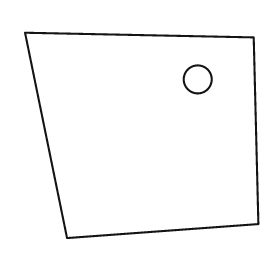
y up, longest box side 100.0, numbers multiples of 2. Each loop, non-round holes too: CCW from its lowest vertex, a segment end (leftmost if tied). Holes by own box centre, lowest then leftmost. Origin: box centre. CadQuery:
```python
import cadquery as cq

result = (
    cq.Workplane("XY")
    .moveTo(-32.0, -44.0)
    .lineTo(50.0, -38.0)
    .lineTo(48.0, 42.0)
    .lineTo(-50.0, 44.0)
    .close()
    .moveTo(24.0, 24.0)
    .circle(6.0)
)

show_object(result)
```